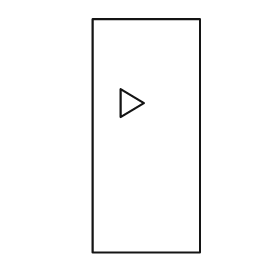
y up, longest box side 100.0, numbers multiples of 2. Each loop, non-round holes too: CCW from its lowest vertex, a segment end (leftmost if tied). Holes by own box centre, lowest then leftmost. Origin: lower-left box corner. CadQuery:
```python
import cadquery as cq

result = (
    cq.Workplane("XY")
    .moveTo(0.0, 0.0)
    .lineTo(46.0, 0.0)
    .lineTo(46.0, 100.0)
    .lineTo(0.0, 100.0)
    .close()
    .moveTo(12.0, 58.0)
    .lineTo(22.0, 64.0)
    .lineTo(12.0, 70.0)
    .close()
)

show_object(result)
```